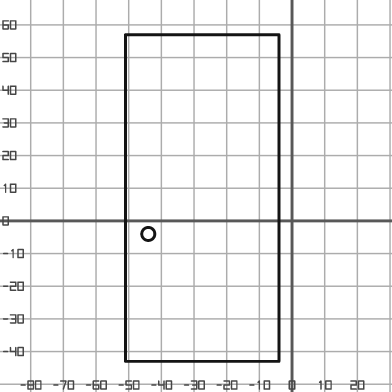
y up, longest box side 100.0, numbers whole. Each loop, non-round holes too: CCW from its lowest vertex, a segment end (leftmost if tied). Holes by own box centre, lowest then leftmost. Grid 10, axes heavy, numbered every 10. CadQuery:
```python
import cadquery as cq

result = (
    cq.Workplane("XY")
    .moveTo(-51.0, -43.0)
    .lineTo(-4.0, -43.0)
    .lineTo(-4.0, 57.0)
    .lineTo(-51.0, 57.0)
    .close()
    .moveTo(-44.0, -4.0)
    .circle(2.0)
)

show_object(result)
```